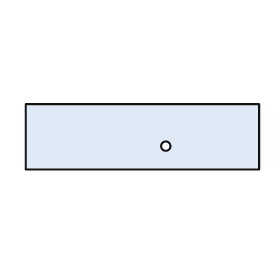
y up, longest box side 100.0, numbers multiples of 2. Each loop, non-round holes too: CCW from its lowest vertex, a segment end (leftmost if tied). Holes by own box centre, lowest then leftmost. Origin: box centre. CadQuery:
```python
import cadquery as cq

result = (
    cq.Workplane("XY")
    .moveTo(-50.0, -14.0)
    .lineTo(50.0, -14.0)
    .lineTo(50.0, 14.0)
    .lineTo(-50.0, 14.0)
    .close()
    .moveTo(10.0, -4.0)
    .circle(2.0)
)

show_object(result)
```